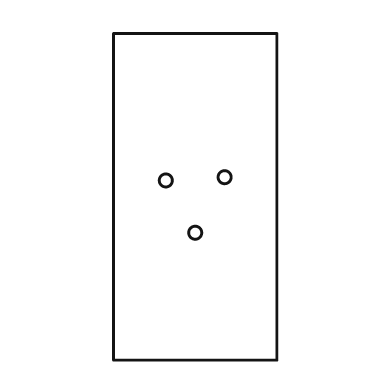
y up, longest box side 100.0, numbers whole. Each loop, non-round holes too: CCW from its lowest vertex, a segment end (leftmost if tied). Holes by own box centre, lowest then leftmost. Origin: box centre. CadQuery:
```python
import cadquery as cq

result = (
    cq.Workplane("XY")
    .moveTo(-25.0, -50.0)
    .lineTo(25.0, -50.0)
    .lineTo(25.0, 50.0)
    .lineTo(-25.0, 50.0)
    .close()
    .moveTo(0.0, -11.0)
    .circle(2.0)
    .moveTo(-9.0, 5.0)
    .circle(2.0)
    .moveTo(9.0, 6.0)
    .circle(2.0)
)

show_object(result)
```